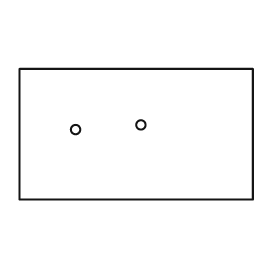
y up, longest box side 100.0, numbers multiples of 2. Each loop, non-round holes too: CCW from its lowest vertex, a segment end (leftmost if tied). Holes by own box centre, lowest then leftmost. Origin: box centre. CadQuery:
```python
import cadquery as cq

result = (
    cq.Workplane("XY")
    .moveTo(-50.0, -28.0)
    .lineTo(50.0, -28.0)
    .lineTo(50.0, 28.0)
    .lineTo(-50.0, 28.0)
    .close()
    .moveTo(-26.0, 2.0)
    .circle(2.0)
    .moveTo(2.0, 4.0)
    .circle(2.0)
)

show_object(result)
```